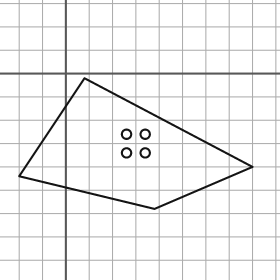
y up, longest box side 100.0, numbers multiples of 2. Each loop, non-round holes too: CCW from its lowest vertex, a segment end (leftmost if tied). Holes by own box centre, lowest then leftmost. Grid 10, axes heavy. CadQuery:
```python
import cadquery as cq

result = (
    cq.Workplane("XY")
    .moveTo(38.0, -58.0)
    .lineTo(80.0, -40.0)
    .lineTo(8.0, -2.0)
    .lineTo(-20.0, -44.0)
    .close()
    .moveTo(26.0, -34.0)
    .circle(2.0)
    .moveTo(34.0, -34.0)
    .circle(2.0)
    .moveTo(26.0, -26.0)
    .circle(2.0)
    .moveTo(34.0, -26.0)
    .circle(2.0)
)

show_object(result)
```